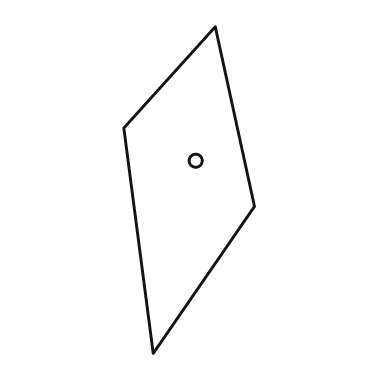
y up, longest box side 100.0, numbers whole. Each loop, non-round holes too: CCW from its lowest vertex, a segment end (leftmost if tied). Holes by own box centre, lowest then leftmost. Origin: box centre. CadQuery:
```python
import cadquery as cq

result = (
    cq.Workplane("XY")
    .moveTo(-11.0, -50.0)
    .lineTo(20.0, -5.0)
    .lineTo(8.0, 50.0)
    .lineTo(-20.0, 19.0)
    .close()
    .moveTo(2.0, 9.0)
    .circle(2.0)
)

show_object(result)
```